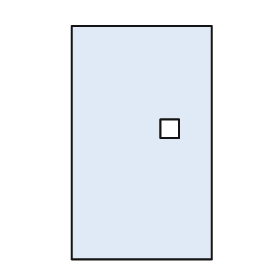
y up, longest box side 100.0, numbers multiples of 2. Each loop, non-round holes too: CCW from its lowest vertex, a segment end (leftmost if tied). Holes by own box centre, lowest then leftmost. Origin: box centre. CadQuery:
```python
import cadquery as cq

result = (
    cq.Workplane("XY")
    .moveTo(-30.0, -50.0)
    .lineTo(30.0, -50.0)
    .lineTo(30.0, 50.0)
    .lineTo(-30.0, 50.0)
    .close()
    .moveTo(8.0, 2.0)
    .lineTo(16.0, 2.0)
    .lineTo(16.0, 10.0)
    .lineTo(8.0, 10.0)
    .close()
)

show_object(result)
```